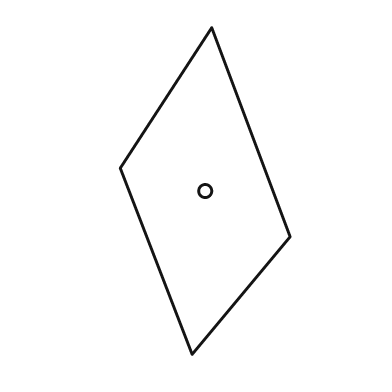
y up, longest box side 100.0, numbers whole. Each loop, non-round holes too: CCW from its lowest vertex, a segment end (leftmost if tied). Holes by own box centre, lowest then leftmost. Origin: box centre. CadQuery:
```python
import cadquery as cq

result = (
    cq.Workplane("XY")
    .moveTo(-4.0, -50.0)
    .lineTo(26.0, -14.0)
    .lineTo(2.0, 50.0)
    .lineTo(-26.0, 7.0)
    .close()
    .moveTo(0.0, 0.0)
    .circle(2.0)
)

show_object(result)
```